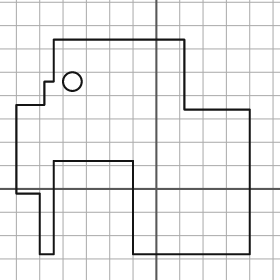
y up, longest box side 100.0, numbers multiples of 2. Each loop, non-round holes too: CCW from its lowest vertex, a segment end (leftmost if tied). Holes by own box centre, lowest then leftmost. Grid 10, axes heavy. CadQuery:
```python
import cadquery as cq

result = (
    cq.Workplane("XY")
    .moveTo(-50.0, -28.0)
    .lineTo(-44.0, -28.0)
    .lineTo(-44.0, 12.0)
    .lineTo(-10.0, 12.0)
    .lineTo(-10.0, -28.0)
    .lineTo(40.0, -28.0)
    .lineTo(40.0, 34.0)
    .lineTo(12.0, 34.0)
    .lineTo(12.0, 64.0)
    .lineTo(-44.0, 64.0)
    .lineTo(-44.0, 46.0)
    .lineTo(-48.0, 46.0)
    .lineTo(-48.0, 36.0)
    .lineTo(-60.0, 36.0)
    .lineTo(-60.0, -2.0)
    .lineTo(-50.0, -2.0)
    .close()
    .moveTo(-36.0, 46.0)
    .circle(4.0)
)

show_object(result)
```